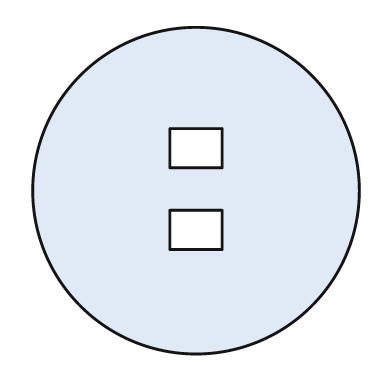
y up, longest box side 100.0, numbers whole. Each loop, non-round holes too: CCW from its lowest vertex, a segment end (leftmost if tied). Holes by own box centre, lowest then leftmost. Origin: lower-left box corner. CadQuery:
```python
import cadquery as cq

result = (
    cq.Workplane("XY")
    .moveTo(50.0, 50.0)
    .circle(50.0)
    .moveTo(42.0, 32.0)
    .lineTo(58.0, 32.0)
    .lineTo(58.0, 44.0)
    .lineTo(42.0, 44.0)
    .close()
    .moveTo(42.0, 57.0)
    .lineTo(58.0, 57.0)
    .lineTo(58.0, 69.0)
    .lineTo(42.0, 69.0)
    .close()
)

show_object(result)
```